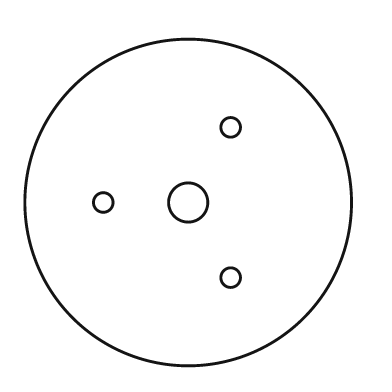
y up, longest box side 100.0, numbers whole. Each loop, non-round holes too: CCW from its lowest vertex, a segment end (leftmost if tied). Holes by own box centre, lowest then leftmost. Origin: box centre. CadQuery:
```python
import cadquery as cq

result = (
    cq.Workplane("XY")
    .moveTo(0.0, 0.0)
    .circle(50.0)
    .moveTo(13.0, -23.0)
    .circle(3.0)
    .moveTo(-26.0, 0.0)
    .circle(3.0)
    .moveTo(0.0, 0.0)
    .circle(6.0)
    .moveTo(13.0, 23.0)
    .circle(3.0)
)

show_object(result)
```